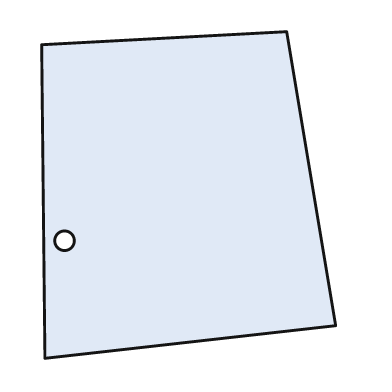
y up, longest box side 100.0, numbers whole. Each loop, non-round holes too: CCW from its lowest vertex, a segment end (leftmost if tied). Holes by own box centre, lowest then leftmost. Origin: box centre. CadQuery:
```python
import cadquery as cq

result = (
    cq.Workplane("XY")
    .moveTo(-44.0, -50.0)
    .lineTo(45.0, -40.0)
    .lineTo(30.0, 50.0)
    .lineTo(-45.0, 46.0)
    .close()
    .moveTo(-38.0, -14.0)
    .circle(3.0)
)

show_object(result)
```